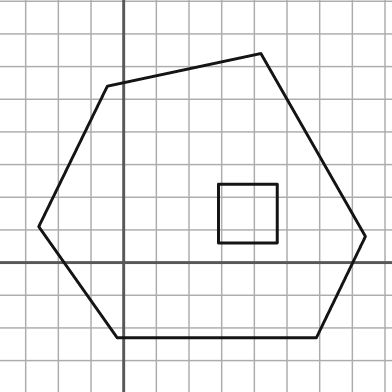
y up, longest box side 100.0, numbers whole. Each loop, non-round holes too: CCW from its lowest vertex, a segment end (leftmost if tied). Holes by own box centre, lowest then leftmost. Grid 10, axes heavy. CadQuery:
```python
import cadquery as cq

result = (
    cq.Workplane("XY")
    .moveTo(-2.0, -23.0)
    .lineTo(59.0, -23.0)
    .lineTo(74.0, 8.0)
    .lineTo(42.0, 64.0)
    .lineTo(-5.0, 54.0)
    .lineTo(-26.0, 11.0)
    .close()
    .moveTo(29.0, 6.0)
    .lineTo(47.0, 6.0)
    .lineTo(47.0, 24.0)
    .lineTo(29.0, 24.0)
    .close()
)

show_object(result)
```